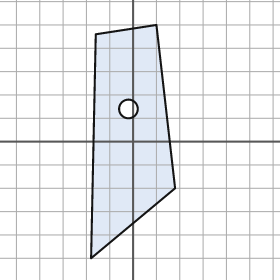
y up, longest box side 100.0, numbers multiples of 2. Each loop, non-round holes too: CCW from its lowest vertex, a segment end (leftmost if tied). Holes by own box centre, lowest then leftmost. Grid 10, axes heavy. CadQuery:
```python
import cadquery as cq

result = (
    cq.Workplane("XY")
    .moveTo(-18.0, -50.0)
    .lineTo(18.0, -20.0)
    .lineTo(10.0, 50.0)
    .lineTo(-16.0, 46.0)
    .close()
    .moveTo(-2.0, 14.0)
    .circle(4.0)
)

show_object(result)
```